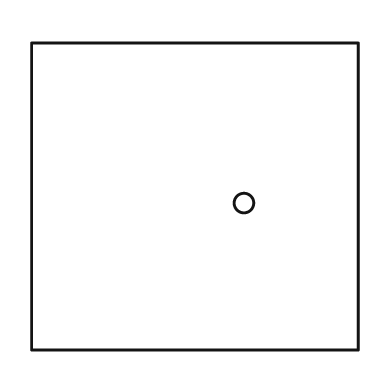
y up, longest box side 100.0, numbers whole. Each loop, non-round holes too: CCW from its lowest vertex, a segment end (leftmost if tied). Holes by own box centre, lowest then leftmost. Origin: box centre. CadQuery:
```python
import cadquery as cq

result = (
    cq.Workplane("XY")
    .moveTo(-50.0, -47.0)
    .lineTo(50.0, -47.0)
    .lineTo(50.0, 47.0)
    .lineTo(-50.0, 47.0)
    .close()
    .moveTo(15.0, -2.0)
    .circle(3.0)
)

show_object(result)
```